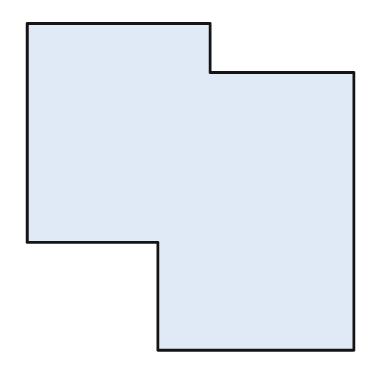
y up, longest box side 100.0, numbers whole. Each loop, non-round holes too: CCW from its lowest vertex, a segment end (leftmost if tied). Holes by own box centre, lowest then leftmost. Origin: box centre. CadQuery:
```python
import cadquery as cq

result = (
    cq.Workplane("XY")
    .moveTo(-10.0, -50.0)
    .lineTo(50.0, -50.0)
    .lineTo(50.0, 35.0)
    .lineTo(6.0, 35.0)
    .lineTo(6.0, 50.0)
    .lineTo(-50.0, 50.0)
    .lineTo(-50.0, -17.0)
    .lineTo(-10.0, -17.0)
    .close()
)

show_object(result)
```